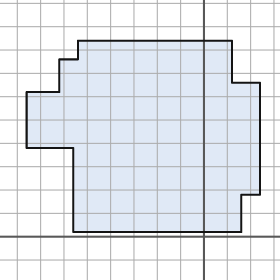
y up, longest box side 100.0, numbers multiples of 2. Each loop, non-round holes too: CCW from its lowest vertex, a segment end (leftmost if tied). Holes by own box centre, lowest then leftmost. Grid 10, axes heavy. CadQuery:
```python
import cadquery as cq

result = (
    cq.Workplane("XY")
    .moveTo(-56.0, 2.0)
    .lineTo(16.0, 2.0)
    .lineTo(16.0, 18.0)
    .lineTo(24.0, 18.0)
    .lineTo(24.0, 66.0)
    .lineTo(12.0, 66.0)
    .lineTo(12.0, 84.0)
    .lineTo(-54.0, 84.0)
    .lineTo(-54.0, 76.0)
    .lineTo(-62.0, 76.0)
    .lineTo(-62.0, 62.0)
    .lineTo(-76.0, 62.0)
    .lineTo(-76.0, 38.0)
    .lineTo(-56.0, 38.0)
    .close()
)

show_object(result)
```